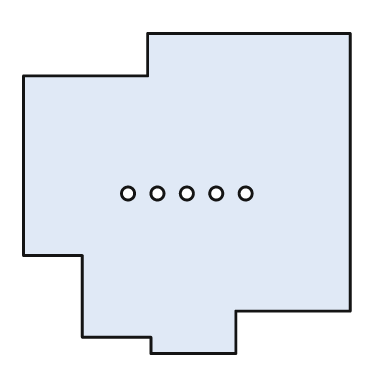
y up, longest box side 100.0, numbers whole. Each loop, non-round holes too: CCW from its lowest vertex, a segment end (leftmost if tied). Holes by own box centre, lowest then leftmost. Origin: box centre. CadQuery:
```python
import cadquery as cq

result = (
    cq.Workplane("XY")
    .moveTo(-11.0, -49.0)
    .lineTo(15.0, -49.0)
    .lineTo(15.0, -36.0)
    .lineTo(50.0, -36.0)
    .lineTo(50.0, 49.0)
    .lineTo(-12.0, 49.0)
    .lineTo(-12.0, 36.0)
    .lineTo(-50.0, 36.0)
    .lineTo(-50.0, -19.0)
    .lineTo(-32.0, -19.0)
    .lineTo(-32.0, -44.0)
    .lineTo(-11.0, -44.0)
    .close()
    .moveTo(-18.0, 0.0)
    .circle(2.0)
    .moveTo(-9.0, 0.0)
    .circle(2.0)
    .moveTo(0.0, 0.0)
    .circle(2.0)
    .moveTo(9.0, 0.0)
    .circle(2.0)
    .moveTo(18.0, 0.0)
    .circle(2.0)
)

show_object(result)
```